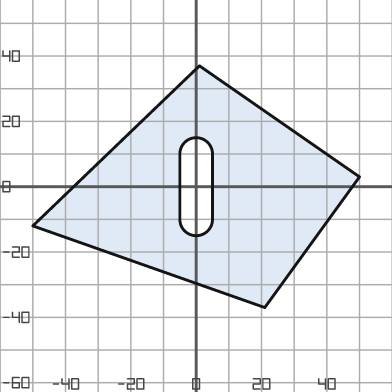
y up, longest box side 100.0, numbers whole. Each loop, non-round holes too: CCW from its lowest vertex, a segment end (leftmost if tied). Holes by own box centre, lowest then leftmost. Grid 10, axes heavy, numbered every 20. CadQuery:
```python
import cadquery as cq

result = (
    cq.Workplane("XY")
    .moveTo(21.0, -37.0)
    .lineTo(50.0, 3.0)
    .lineTo(1.0, 37.0)
    .lineTo(-50.0, -12.0)
    .close()
    .moveTo(-5.0, -10.0)
    .threePointArc((0.0, -15.0), (5.0, -10.0))
    .lineTo(5.0, 10.0)
    .threePointArc((0.0, 15.0), (-5.0, 10.0))
    .close()
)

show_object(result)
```